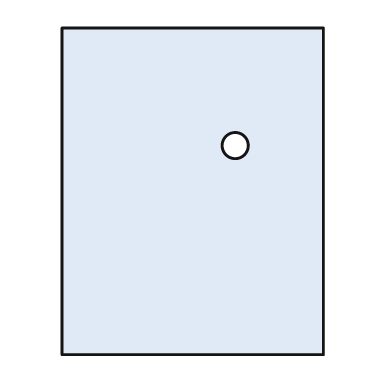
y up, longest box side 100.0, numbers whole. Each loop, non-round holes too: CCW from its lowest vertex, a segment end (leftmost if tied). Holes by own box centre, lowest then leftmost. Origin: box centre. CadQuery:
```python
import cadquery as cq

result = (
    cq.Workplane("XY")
    .moveTo(-40.0, -50.0)
    .lineTo(40.0, -50.0)
    .lineTo(40.0, 50.0)
    .lineTo(-40.0, 50.0)
    .close()
    .moveTo(13.0, 14.0)
    .circle(4.0)
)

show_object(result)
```